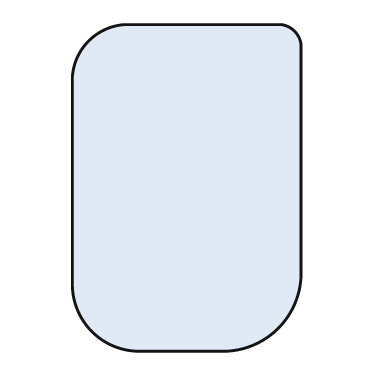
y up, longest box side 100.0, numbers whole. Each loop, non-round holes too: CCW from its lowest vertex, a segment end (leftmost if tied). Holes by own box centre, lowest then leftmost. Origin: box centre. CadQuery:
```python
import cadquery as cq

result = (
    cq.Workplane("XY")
    .moveTo(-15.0, -50.0)
    .lineTo(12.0, -50.0)
    .threePointArc((28.0, -43.0), (35.0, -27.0))
    .lineTo(35.0, 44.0)
    .threePointArc((33.0, 48.0), (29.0, 50.0))
    .lineTo(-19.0, 50.0)
    .threePointArc((-30.0, 45.0), (-35.0, 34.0))
    .lineTo(-35.0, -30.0)
    .threePointArc((-29.0, -44.0), (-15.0, -50.0))
    .close()
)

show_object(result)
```